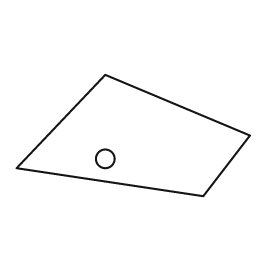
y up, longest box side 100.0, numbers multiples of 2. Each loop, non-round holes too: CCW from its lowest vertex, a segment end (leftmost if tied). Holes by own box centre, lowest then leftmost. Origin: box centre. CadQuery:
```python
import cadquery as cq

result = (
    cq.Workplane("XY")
    .moveTo(30.0, -26.0)
    .lineTo(50.0, 0.0)
    .lineTo(-12.0, 26.0)
    .lineTo(-50.0, -14.0)
    .close()
    .moveTo(-12.0, -10.0)
    .circle(4.0)
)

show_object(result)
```